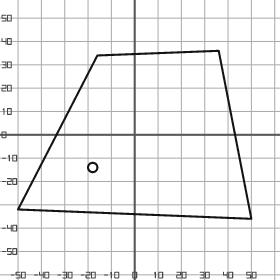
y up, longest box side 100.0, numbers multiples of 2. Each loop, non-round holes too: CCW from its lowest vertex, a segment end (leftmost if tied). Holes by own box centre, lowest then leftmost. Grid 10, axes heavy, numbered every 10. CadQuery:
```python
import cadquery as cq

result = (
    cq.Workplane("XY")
    .moveTo(50.0, -36.0)
    .lineTo(36.0, 36.0)
    .lineTo(-16.0, 34.0)
    .lineTo(-50.0, -32.0)
    .close()
    .moveTo(-18.0, -14.0)
    .circle(2.0)
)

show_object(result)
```